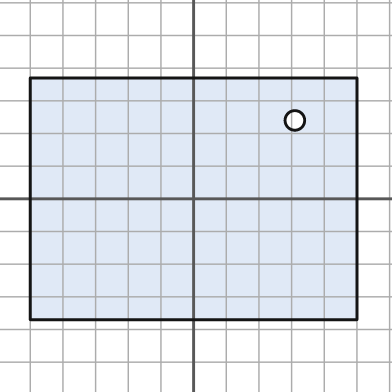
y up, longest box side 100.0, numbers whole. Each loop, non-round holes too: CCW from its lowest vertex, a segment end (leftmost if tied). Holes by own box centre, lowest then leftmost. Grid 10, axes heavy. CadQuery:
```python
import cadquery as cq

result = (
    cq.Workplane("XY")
    .moveTo(-50.0, -37.0)
    .lineTo(50.0, -37.0)
    .lineTo(50.0, 37.0)
    .lineTo(-50.0, 37.0)
    .close()
    .moveTo(31.0, 24.0)
    .circle(3.0)
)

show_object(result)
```